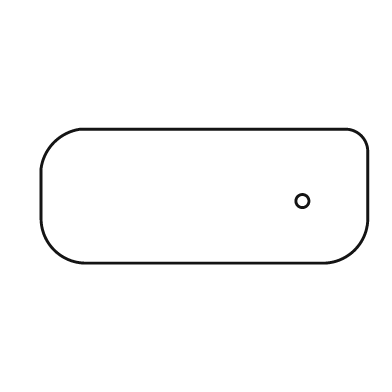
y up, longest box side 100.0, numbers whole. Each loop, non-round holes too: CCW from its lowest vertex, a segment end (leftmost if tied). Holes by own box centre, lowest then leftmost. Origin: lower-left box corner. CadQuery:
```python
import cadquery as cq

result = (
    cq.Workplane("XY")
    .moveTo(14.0, 0.0)
    .lineTo(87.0, 0.0)
    .threePointArc((96.0, 4.0), (100.0, 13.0))
    .lineTo(100.0, 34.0)
    .threePointArc((98.0, 39.0), (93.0, 41.0))
    .lineTo(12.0, 41.0)
    .threePointArc((4.0, 37.0), (0.0, 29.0))
    .lineTo(0.0, 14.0)
    .threePointArc((4.0, 4.0), (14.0, 0.0))
    .close()
    .moveTo(80.0, 19.0)
    .circle(2.0)
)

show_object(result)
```